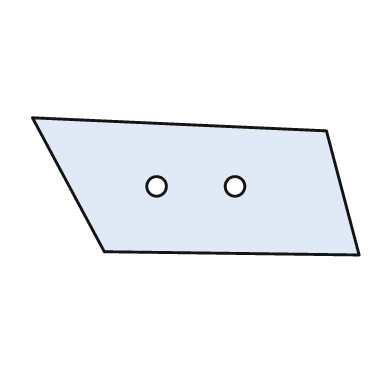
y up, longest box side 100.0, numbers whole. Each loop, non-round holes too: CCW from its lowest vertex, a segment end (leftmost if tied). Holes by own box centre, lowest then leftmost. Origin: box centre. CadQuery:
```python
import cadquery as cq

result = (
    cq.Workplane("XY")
    .moveTo(50.0, -21.0)
    .lineTo(40.0, 17.0)
    .lineTo(-50.0, 21.0)
    .lineTo(-28.0, -20.0)
    .close()
    .moveTo(-12.0, 0.0)
    .circle(3.0)
    .moveTo(12.0, 0.0)
    .circle(3.0)
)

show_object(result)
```